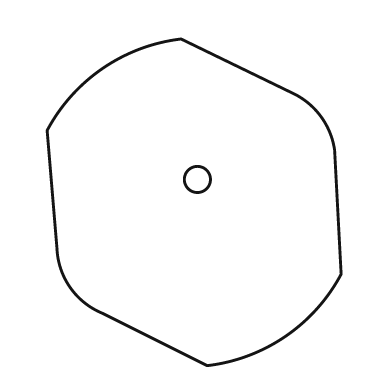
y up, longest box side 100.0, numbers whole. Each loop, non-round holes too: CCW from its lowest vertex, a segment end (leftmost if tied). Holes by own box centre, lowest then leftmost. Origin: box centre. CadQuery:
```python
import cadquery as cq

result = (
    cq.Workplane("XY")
    .moveTo(4.0, -50.0)
    .threePointArc((28.0, -41.0), (45.0, -22.0))
    .lineTo(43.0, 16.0)
    .threePointArc((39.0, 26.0), (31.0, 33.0))
    .lineTo(-4.0, 50.0)
    .threePointArc((-28.0, 41.0), (-45.0, 22.0))
    .lineTo(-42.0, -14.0)
    .threePointArc((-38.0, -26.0), (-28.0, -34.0))
    .close()
    .moveTo(1.0, 7.0)
    .circle(4.0)
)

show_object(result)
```